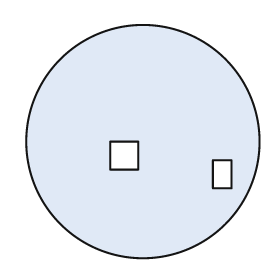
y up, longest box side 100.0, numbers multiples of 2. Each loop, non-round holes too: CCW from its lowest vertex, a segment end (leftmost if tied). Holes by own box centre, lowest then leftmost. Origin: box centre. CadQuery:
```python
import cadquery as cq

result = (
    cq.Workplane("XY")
    .moveTo(0.0, 0.0)
    .circle(50.0)
    .moveTo(30.0, -20.0)
    .lineTo(38.0, -20.0)
    .lineTo(38.0, -8.0)
    .lineTo(30.0, -8.0)
    .close()
    .moveTo(-14.0, -12.0)
    .lineTo(-2.0, -12.0)
    .lineTo(-2.0, 0.0)
    .lineTo(-14.0, 0.0)
    .close()
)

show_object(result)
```